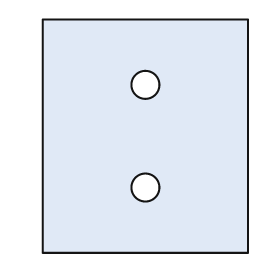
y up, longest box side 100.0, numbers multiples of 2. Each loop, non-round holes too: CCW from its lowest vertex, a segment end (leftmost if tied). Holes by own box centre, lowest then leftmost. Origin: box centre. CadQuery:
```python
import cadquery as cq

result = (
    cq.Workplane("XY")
    .moveTo(-44.0, -50.0)
    .lineTo(44.0, -50.0)
    .lineTo(44.0, 50.0)
    .lineTo(-44.0, 50.0)
    .close()
    .moveTo(0.0, -22.0)
    .circle(6.0)
    .moveTo(0.0, 22.0)
    .circle(6.0)
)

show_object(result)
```